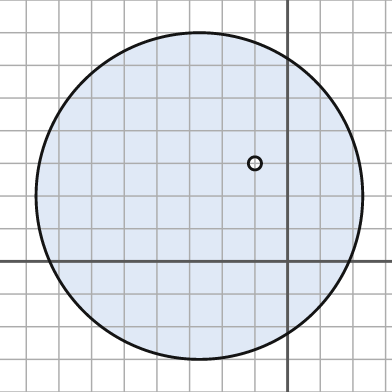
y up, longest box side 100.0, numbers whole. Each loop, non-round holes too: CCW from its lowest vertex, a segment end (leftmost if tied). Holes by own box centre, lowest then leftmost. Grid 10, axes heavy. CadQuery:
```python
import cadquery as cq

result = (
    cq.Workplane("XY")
    .moveTo(-27.0, 20.0)
    .circle(50.0)
    .moveTo(-10.0, 30.0)
    .circle(2.0)
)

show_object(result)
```